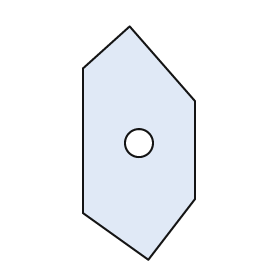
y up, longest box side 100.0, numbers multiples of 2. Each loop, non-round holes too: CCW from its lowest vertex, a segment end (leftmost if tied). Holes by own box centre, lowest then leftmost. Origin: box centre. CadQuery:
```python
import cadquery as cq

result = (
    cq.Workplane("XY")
    .moveTo(4.0, -50.0)
    .lineTo(24.0, -24.0)
    .lineTo(24.0, 18.0)
    .lineTo(-4.0, 50.0)
    .lineTo(-24.0, 32.0)
    .lineTo(-24.0, -30.0)
    .close()
    .moveTo(0.0, 0.0)
    .circle(6.0)
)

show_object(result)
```